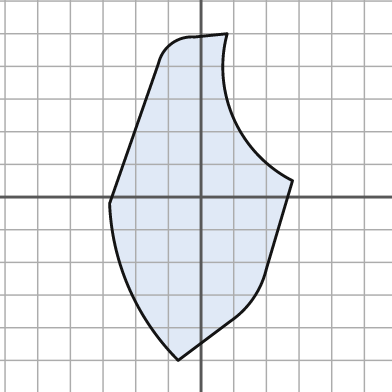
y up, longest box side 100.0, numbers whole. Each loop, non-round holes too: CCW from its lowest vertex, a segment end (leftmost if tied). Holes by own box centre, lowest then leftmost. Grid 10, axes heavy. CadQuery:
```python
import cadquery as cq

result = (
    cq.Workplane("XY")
    .moveTo(-7.0, -50.0)
    .lineTo(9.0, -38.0)
    .threePointArc((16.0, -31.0), (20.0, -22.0))
    .lineTo(28.0, 5.0)
    .threePointArc((10.0, 24.0), (8.0, 50.0))
    .lineTo(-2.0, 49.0)
    .threePointArc((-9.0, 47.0), (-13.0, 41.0))
    .lineTo(-28.0, -2.0)
    .threePointArc((-22.0, -28.0), (-7.0, -50.0))
    .close()
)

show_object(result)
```